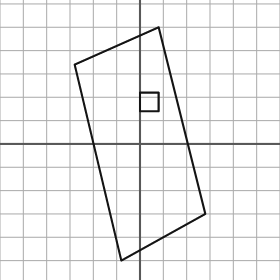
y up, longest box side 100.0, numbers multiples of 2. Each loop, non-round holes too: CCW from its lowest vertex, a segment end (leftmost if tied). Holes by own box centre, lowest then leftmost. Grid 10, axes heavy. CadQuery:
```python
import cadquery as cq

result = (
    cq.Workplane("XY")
    .moveTo(-8.0, -50.0)
    .lineTo(28.0, -30.0)
    .lineTo(8.0, 50.0)
    .lineTo(-28.0, 34.0)
    .close()
    .moveTo(0.0, 14.0)
    .lineTo(8.0, 14.0)
    .lineTo(8.0, 22.0)
    .lineTo(0.0, 22.0)
    .close()
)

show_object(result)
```